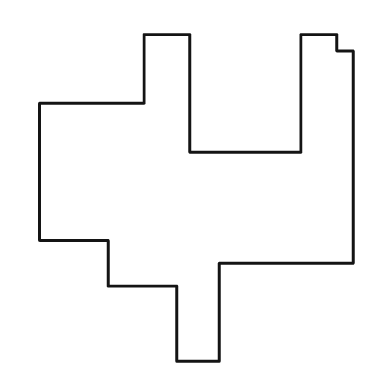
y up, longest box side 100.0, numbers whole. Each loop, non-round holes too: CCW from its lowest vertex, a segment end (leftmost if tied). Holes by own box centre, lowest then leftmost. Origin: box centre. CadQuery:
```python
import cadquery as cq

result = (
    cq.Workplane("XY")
    .moveTo(-6.0, -50.0)
    .lineTo(7.0, -50.0)
    .lineTo(7.0, -20.0)
    .lineTo(48.0, -20.0)
    .lineTo(48.0, 45.0)
    .lineTo(43.0, 45.0)
    .lineTo(43.0, 50.0)
    .lineTo(32.0, 50.0)
    .lineTo(32.0, 14.0)
    .lineTo(-2.0, 14.0)
    .lineTo(-2.0, 50.0)
    .lineTo(-16.0, 50.0)
    .lineTo(-16.0, 29.0)
    .lineTo(-48.0, 29.0)
    .lineTo(-48.0, -13.0)
    .lineTo(-27.0, -13.0)
    .lineTo(-27.0, -27.0)
    .lineTo(-6.0, -27.0)
    .close()
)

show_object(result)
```